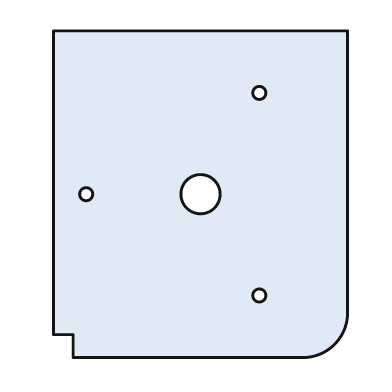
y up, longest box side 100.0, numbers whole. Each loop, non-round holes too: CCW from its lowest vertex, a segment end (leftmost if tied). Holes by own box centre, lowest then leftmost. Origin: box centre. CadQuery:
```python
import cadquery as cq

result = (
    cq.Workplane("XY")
    .moveTo(-39.0, -50.0)
    .lineTo(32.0, -50.0)
    .threePointArc((41.0, -46.0), (45.0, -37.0))
    .lineTo(45.0, 50.0)
    .lineTo(-45.0, 50.0)
    .lineTo(-45.0, -43.0)
    .lineTo(-39.0, -43.0)
    .close()
    .moveTo(18.0, -31.0)
    .circle(2.0)
    .moveTo(-35.0, 0.0)
    .circle(2.0)
    .moveTo(0.0, 0.0)
    .circle(6.0)
    .moveTo(18.0, 31.0)
    .circle(2.0)
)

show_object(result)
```